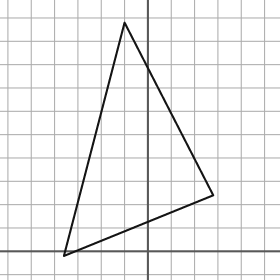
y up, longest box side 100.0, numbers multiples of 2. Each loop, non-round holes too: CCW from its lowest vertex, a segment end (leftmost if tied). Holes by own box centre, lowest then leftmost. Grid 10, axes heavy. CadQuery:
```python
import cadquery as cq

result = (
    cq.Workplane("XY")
    .moveTo(-36.0, -2.0)
    .lineTo(28.0, 24.0)
    .lineTo(-10.0, 98.0)
    .close()
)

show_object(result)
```